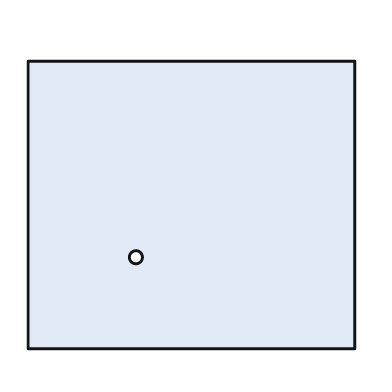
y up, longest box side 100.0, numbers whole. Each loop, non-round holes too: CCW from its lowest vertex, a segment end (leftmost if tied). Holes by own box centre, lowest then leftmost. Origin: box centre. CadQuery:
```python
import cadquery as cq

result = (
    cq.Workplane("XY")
    .moveTo(-50.0, -44.0)
    .lineTo(50.0, -44.0)
    .lineTo(50.0, 44.0)
    .lineTo(-50.0, 44.0)
    .close()
    .moveTo(-17.0, -16.0)
    .circle(2.0)
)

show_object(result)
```